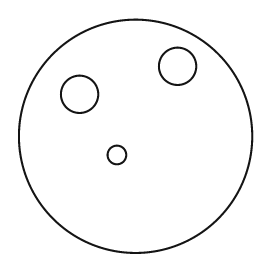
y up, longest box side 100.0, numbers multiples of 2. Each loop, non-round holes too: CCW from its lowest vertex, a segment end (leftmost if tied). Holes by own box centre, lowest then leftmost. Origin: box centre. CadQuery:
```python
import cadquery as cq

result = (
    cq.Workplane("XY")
    .moveTo(0.0, 0.0)
    .circle(50.0)
    .moveTo(-8.0, -8.0)
    .circle(4.0)
    .moveTo(-24.0, 18.0)
    .circle(8.0)
    .moveTo(18.0, 30.0)
    .circle(8.0)
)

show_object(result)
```